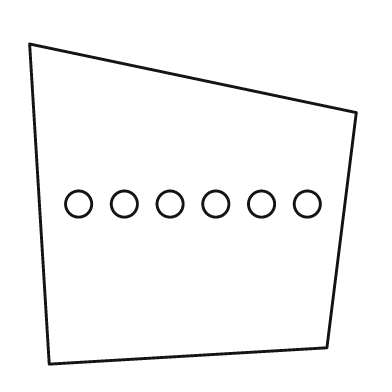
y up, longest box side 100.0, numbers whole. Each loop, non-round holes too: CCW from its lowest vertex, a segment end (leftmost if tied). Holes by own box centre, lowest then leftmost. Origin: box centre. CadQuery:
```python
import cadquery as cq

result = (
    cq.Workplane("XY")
    .moveTo(-44.0, -49.0)
    .lineTo(41.0, -44.0)
    .lineTo(50.0, 28.0)
    .lineTo(-50.0, 49.0)
    .close()
    .moveTo(-35.0, 0.0)
    .circle(4.0)
    .moveTo(-21.0, 0.0)
    .circle(4.0)
    .moveTo(-7.0, 0.0)
    .circle(4.0)
    .moveTo(7.0, 0.0)
    .circle(4.0)
    .moveTo(21.0, 0.0)
    .circle(4.0)
    .moveTo(35.0, 0.0)
    .circle(4.0)
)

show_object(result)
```